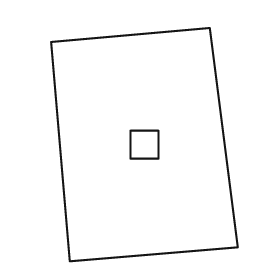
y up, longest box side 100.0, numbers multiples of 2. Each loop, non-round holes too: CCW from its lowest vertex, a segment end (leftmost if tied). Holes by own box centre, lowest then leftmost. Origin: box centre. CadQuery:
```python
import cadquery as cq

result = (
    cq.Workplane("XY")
    .moveTo(-32.0, -50.0)
    .lineTo(40.0, -44.0)
    .lineTo(28.0, 50.0)
    .lineTo(-40.0, 44.0)
    .close()
    .moveTo(-6.0, -6.0)
    .lineTo(6.0, -6.0)
    .lineTo(6.0, 6.0)
    .lineTo(-6.0, 6.0)
    .close()
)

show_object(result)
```